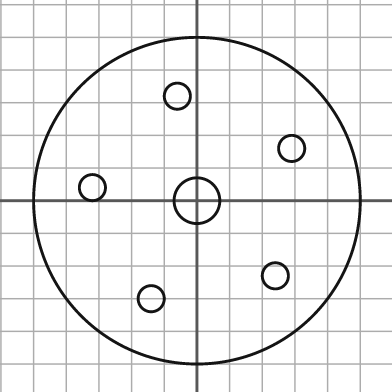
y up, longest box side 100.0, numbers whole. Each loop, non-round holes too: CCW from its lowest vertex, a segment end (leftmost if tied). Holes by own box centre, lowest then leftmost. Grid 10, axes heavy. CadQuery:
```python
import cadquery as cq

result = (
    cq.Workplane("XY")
    .moveTo(0.0, 0.0)
    .circle(50.0)
    .moveTo(-14.0, -30.0)
    .circle(4.0)
    .moveTo(24.0, -23.0)
    .circle(4.0)
    .moveTo(0.0, 0.0)
    .circle(7.0)
    .moveTo(-32.0, 4.0)
    .circle(4.0)
    .moveTo(29.0, 16.0)
    .circle(4.0)
    .moveTo(-6.0, 32.0)
    .circle(4.0)
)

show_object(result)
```